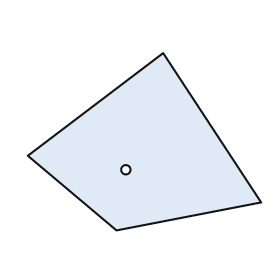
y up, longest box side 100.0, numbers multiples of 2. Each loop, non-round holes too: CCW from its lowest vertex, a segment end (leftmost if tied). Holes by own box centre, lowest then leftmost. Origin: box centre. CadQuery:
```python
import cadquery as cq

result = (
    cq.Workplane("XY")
    .moveTo(-12.0, -38.0)
    .lineTo(50.0, -26.0)
    .lineTo(8.0, 38.0)
    .lineTo(-50.0, -6.0)
    .close()
    .moveTo(-8.0, -12.0)
    .circle(2.0)
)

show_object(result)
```